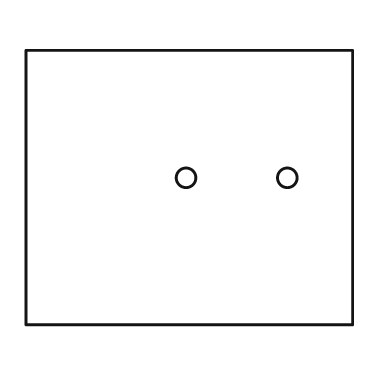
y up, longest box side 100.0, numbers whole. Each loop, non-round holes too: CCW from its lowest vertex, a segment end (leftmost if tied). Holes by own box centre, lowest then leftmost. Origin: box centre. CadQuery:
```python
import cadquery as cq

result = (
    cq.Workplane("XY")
    .moveTo(-50.0, -42.0)
    .lineTo(50.0, -42.0)
    .lineTo(50.0, 42.0)
    .lineTo(-50.0, 42.0)
    .close()
    .moveTo(-1.0, 3.0)
    .circle(3.0)
    .moveTo(30.0, 3.0)
    .circle(3.0)
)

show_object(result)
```